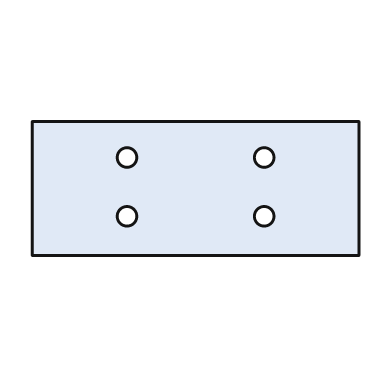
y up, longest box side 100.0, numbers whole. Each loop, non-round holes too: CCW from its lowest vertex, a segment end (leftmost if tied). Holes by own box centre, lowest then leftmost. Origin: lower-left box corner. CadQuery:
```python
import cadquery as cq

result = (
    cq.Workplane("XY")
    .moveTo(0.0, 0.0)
    .lineTo(100.0, 0.0)
    .lineTo(100.0, 41.0)
    .lineTo(0.0, 41.0)
    .close()
    .moveTo(29.0, 12.0)
    .circle(3.0)
    .moveTo(71.0, 12.0)
    .circle(3.0)
    .moveTo(29.0, 30.0)
    .circle(3.0)
    .moveTo(71.0, 30.0)
    .circle(3.0)
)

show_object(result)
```